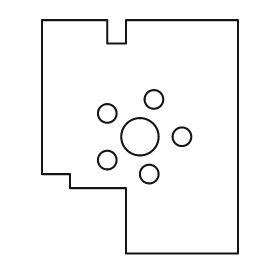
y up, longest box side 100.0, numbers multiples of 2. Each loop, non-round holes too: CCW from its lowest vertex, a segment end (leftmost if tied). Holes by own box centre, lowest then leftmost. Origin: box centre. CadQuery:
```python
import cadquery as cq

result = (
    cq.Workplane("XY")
    .moveTo(-6.0, -50.0)
    .lineTo(42.0, -50.0)
    .lineTo(42.0, 50.0)
    .lineTo(-6.0, 50.0)
    .lineTo(-6.0, 40.0)
    .lineTo(-14.0, 40.0)
    .lineTo(-14.0, 50.0)
    .lineTo(-42.0, 50.0)
    .lineTo(-42.0, -16.0)
    .lineTo(-30.0, -16.0)
    .lineTo(-30.0, -22.0)
    .lineTo(-6.0, -22.0)
    .close()
    .moveTo(4.0, -16.0)
    .circle(4.0)
    .moveTo(-14.0, -10.0)
    .circle(4.0)
    .moveTo(0.0, 0.0)
    .circle(8.0)
    .moveTo(18.0, 0.0)
    .circle(4.0)
    .moveTo(-14.0, 10.0)
    .circle(4.0)
    .moveTo(6.0, 16.0)
    .circle(4.0)
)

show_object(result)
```